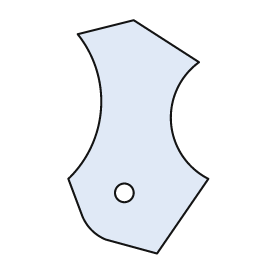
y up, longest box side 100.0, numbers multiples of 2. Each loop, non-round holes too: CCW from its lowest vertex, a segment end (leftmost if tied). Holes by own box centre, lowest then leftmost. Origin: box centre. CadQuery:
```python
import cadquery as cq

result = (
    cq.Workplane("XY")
    .moveTo(8.0, -50.0)
    .lineTo(30.0, -18.0)
    .threePointArc((14.0, 6.0), (26.0, 32.0))
    .lineTo(-2.0, 50.0)
    .lineTo(-26.0, 44.0)
    .threePointArc((-16.0, 12.0), (-30.0, -18.0))
    .lineTo(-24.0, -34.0)
    .threePointArc((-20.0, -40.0), (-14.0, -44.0))
    .close()
    .moveTo(-6.0, -24.0)
    .circle(4.0)
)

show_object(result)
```